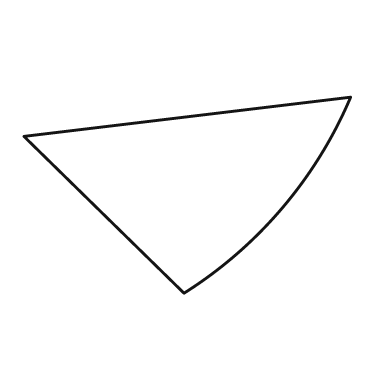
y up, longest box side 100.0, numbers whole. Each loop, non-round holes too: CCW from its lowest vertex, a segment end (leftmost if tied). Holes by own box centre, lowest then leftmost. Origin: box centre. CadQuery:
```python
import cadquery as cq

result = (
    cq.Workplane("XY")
    .moveTo(-1.0, -30.0)
    .threePointArc((29.0, -4.0), (50.0, 30.0))
    .lineTo(-50.0, 18.0)
    .close()
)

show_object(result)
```